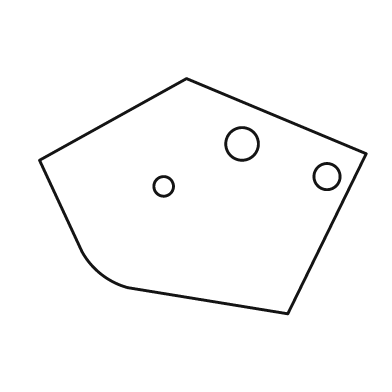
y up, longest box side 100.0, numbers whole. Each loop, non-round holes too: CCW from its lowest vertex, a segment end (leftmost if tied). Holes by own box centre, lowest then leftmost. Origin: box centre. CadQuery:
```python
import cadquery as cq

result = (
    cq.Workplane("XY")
    .moveTo(26.0, -36.0)
    .lineTo(50.0, 13.0)
    .lineTo(-5.0, 36.0)
    .lineTo(-50.0, 11.0)
    .lineTo(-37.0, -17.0)
    .threePointArc((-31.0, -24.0), (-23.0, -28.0))
    .close()
    .moveTo(-12.0, 3.0)
    .circle(3.0)
    .moveTo(38.0, 6.0)
    .circle(4.0)
    .moveTo(12.0, 16.0)
    .circle(5.0)
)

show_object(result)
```